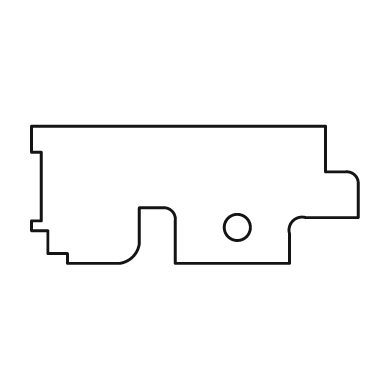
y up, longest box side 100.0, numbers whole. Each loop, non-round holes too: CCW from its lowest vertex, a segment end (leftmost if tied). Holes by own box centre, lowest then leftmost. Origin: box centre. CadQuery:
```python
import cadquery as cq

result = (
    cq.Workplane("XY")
    .moveTo(-39.0, -21.0)
    .lineTo(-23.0, -21.0)
    .threePointArc((-19.0, -19.0), (-17.0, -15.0))
    .lineTo(-17.0, -4.0)
    .lineTo(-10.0, -4.0)
    .threePointArc((-7.0, -5.0), (-6.0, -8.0))
    .lineTo(-6.0, -21.0)
    .lineTo(29.0, -21.0)
    .lineTo(29.0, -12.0)
    .threePointArc((30.0, -8.0), (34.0, -7.0))
    .lineTo(50.0, -7.0)
    .lineTo(50.0, 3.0)
    .threePointArc((49.0, 6.0), (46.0, 7.0))
    .lineTo(40.0, 7.0)
    .lineTo(40.0, 21.0)
    .lineTo(-50.0, 21.0)
    .lineTo(-50.0, 13.0)
    .lineTo(-47.0, 13.0)
    .lineTo(-47.0, -8.0)
    .lineTo(-50.0, -8.0)
    .lineTo(-50.0, -11.0)
    .lineTo(-45.0, -11.0)
    .lineTo(-45.0, -18.0)
    .lineTo(-39.0, -18.0)
    .close()
    .moveTo(13.0, -10.0)
    .circle(4.0)
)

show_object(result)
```